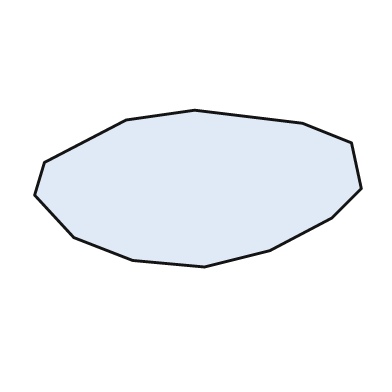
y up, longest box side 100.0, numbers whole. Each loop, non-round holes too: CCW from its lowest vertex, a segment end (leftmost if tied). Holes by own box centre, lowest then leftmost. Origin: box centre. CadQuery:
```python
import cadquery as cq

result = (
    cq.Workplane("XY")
    .moveTo(2.0, -24.0)
    .lineTo(22.0, -19.0)
    .lineTo(41.0, -9.0)
    .lineTo(50.0, 0.0)
    .lineTo(47.0, 14.0)
    .lineTo(32.0, 20.0)
    .lineTo(-1.0, 24.0)
    .lineTo(-22.0, 21.0)
    .lineTo(-47.0, 8.0)
    .lineTo(-50.0, -2.0)
    .lineTo(-38.0, -15.0)
    .lineTo(-20.0, -22.0)
    .close()
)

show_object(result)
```